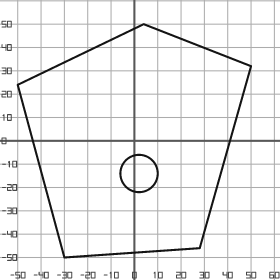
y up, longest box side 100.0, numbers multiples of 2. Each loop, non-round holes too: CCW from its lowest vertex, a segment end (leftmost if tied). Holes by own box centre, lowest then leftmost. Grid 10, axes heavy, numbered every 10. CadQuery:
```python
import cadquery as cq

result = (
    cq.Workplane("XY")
    .moveTo(-30.0, -50.0)
    .lineTo(28.0, -46.0)
    .lineTo(50.0, 32.0)
    .lineTo(4.0, 50.0)
    .lineTo(-50.0, 24.0)
    .close()
    .moveTo(2.0, -14.0)
    .circle(8.0)
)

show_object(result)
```